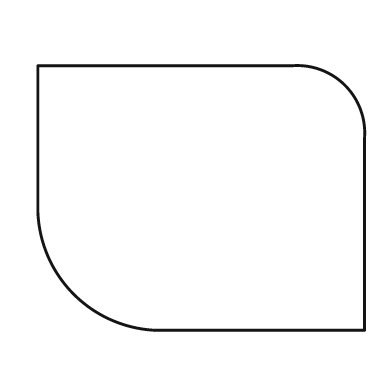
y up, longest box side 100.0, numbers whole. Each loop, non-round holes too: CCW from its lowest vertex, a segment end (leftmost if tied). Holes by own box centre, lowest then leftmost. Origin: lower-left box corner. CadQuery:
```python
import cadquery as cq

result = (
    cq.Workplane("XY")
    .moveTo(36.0, 0.0)
    .lineTo(100.0, 0.0)
    .lineTo(100.0, 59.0)
    .threePointArc((94.0, 75.0), (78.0, 81.0))
    .lineTo(0.0, 81.0)
    .lineTo(0.0, 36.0)
    .threePointArc((11.0, 11.0), (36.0, 0.0))
    .close()
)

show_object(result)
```